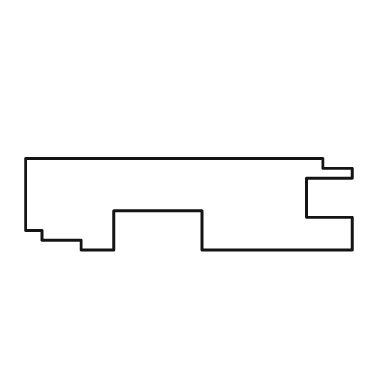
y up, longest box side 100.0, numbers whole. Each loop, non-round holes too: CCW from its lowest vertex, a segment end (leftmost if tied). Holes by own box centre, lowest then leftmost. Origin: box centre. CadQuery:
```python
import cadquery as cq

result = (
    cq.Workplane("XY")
    .moveTo(-33.0, -14.0)
    .lineTo(-23.0, -14.0)
    .lineTo(-23.0, -2.0)
    .lineTo(4.0, -2.0)
    .lineTo(4.0, -14.0)
    .lineTo(50.0, -14.0)
    .lineTo(50.0, -4.0)
    .lineTo(36.0, -4.0)
    .lineTo(36.0, 8.0)
    .lineTo(50.0, 8.0)
    .lineTo(50.0, 11.0)
    .lineTo(41.0, 11.0)
    .lineTo(41.0, 14.0)
    .lineTo(-50.0, 14.0)
    .lineTo(-50.0, -8.0)
    .lineTo(-45.0, -8.0)
    .lineTo(-45.0, -11.0)
    .lineTo(-33.0, -11.0)
    .close()
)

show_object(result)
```